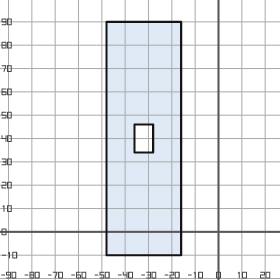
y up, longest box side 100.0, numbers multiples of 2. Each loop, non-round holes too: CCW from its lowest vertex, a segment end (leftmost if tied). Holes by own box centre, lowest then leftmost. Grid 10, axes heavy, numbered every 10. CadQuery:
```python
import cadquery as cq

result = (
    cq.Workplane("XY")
    .moveTo(-48.0, -10.0)
    .lineTo(-16.0, -10.0)
    .lineTo(-16.0, 90.0)
    .lineTo(-48.0, 90.0)
    .close()
    .moveTo(-36.0, 34.0)
    .lineTo(-28.0, 34.0)
    .lineTo(-28.0, 46.0)
    .lineTo(-36.0, 46.0)
    .close()
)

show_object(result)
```